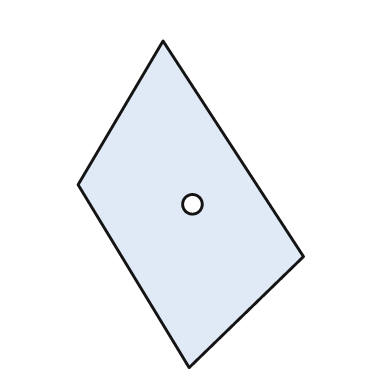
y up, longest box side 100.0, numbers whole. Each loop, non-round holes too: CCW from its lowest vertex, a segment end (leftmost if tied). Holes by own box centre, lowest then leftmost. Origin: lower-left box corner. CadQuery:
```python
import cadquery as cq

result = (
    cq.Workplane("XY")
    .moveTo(34.0, 0.0)
    .lineTo(69.0, 34.0)
    .lineTo(26.0, 100.0)
    .lineTo(0.0, 56.0)
    .close()
    .moveTo(35.0, 50.0)
    .circle(3.0)
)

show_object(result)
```